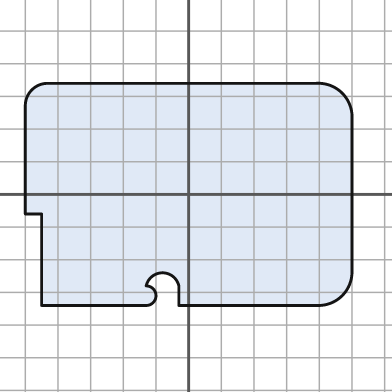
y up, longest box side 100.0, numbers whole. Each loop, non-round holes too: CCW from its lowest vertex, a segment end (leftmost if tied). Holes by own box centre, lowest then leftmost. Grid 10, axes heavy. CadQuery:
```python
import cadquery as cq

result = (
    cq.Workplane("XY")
    .moveTo(-45.0, -34.0)
    .lineTo(-13.0, -34.0)
    .threePointArc((-10.0, -31.0), (-13.0, -28.0))
    .threePointArc((-8.0, -24.0), (-3.0, -28.0))
    .lineTo(-3.0, -34.0)
    .lineTo(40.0, -34.0)
    .threePointArc((47.0, -31.0), (50.0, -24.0))
    .lineTo(50.0, 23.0)
    .threePointArc((47.0, 31.0), (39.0, 34.0))
    .lineTo(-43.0, 34.0)
    .threePointArc((-48.0, 32.0), (-50.0, 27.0))
    .lineTo(-50.0, -6.0)
    .lineTo(-45.0, -6.0)
    .close()
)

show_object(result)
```